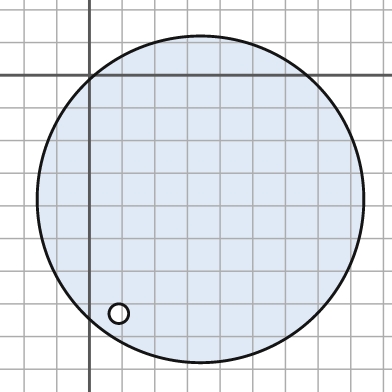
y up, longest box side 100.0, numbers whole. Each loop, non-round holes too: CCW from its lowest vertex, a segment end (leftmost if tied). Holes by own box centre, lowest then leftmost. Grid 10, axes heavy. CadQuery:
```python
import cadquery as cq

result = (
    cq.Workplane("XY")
    .moveTo(34.0, -38.0)
    .circle(50.0)
    .moveTo(9.0, -73.0)
    .circle(3.0)
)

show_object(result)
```